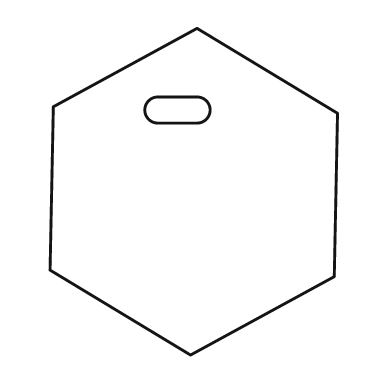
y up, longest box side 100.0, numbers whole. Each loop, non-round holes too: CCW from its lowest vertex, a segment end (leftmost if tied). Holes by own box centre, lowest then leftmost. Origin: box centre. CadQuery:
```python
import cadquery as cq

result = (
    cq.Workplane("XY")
    .moveTo(-1.0, -50.0)
    .lineTo(43.0, -26.0)
    .lineTo(44.0, 24.0)
    .lineTo(1.0, 50.0)
    .lineTo(-43.0, 26.0)
    .lineTo(-44.0, -24.0)
    .close()
    .moveTo(-11.0, 21.0)
    .lineTo(1.0, 21.0)
    .threePointArc((5.0, 25.0), (1.0, 29.0))
    .lineTo(-11.0, 29.0)
    .threePointArc((-15.0, 25.0), (-11.0, 21.0))
    .close()
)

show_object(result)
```